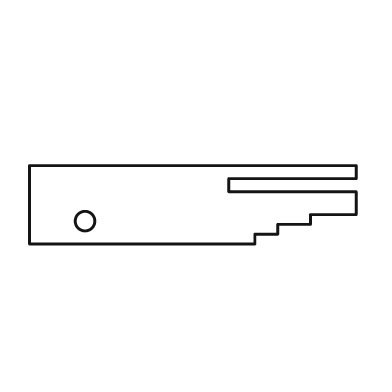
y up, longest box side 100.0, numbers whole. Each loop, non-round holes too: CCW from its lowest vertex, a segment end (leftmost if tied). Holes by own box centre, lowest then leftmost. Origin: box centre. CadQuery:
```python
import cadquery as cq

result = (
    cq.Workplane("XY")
    .moveTo(-50.0, -12.0)
    .lineTo(19.0, -12.0)
    .lineTo(19.0, -9.0)
    .lineTo(26.0, -9.0)
    .lineTo(26.0, -6.0)
    .lineTo(36.0, -6.0)
    .lineTo(36.0, -3.0)
    .lineTo(50.0, -3.0)
    .lineTo(50.0, 4.0)
    .lineTo(11.0, 4.0)
    .lineTo(11.0, 8.0)
    .lineTo(50.0, 8.0)
    .lineTo(50.0, 12.0)
    .lineTo(-50.0, 12.0)
    .close()
    .moveTo(-33.0, -5.0)
    .circle(3.0)
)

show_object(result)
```